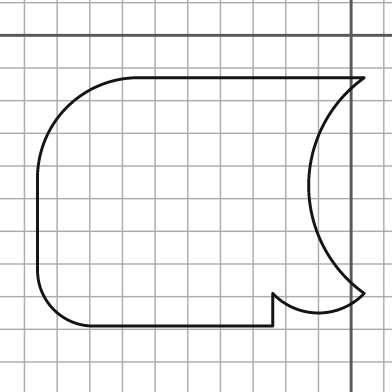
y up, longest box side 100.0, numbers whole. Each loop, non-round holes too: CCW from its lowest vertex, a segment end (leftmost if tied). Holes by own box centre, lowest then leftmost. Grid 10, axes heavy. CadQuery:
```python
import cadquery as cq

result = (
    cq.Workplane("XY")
    .moveTo(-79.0, -89.0)
    .lineTo(-24.0, -89.0)
    .lineTo(-24.0, -79.0)
    .threePointArc((-10.0, -85.0), (4.0, -79.0))
    .threePointArc((-13.0, -46.0), (4.0, -13.0))
    .lineTo(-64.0, -13.0)
    .threePointArc((-87.0, -22.0), (-96.0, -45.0))
    .lineTo(-96.0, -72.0)
    .threePointArc((-91.0, -84.0), (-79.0, -89.0))
    .close()
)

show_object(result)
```